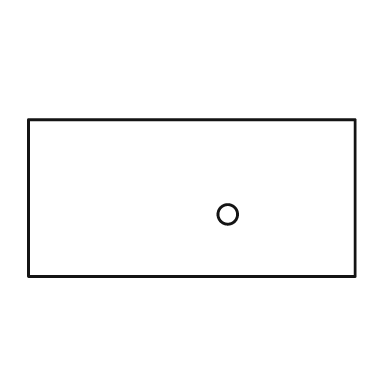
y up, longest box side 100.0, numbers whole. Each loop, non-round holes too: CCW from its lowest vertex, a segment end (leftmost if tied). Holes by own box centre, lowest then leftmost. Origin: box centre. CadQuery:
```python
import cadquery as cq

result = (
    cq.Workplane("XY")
    .moveTo(-50.0, -24.0)
    .lineTo(50.0, -24.0)
    .lineTo(50.0, 24.0)
    .lineTo(-50.0, 24.0)
    .close()
    .moveTo(11.0, -5.0)
    .circle(3.0)
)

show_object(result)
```